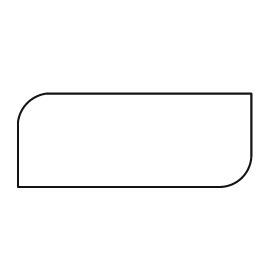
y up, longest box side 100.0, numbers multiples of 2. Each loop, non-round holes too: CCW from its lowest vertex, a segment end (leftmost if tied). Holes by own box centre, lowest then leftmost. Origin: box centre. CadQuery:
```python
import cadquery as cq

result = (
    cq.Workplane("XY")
    .moveTo(-50.0, -20.0)
    .lineTo(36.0, -20.0)
    .threePointArc((46.0, -16.0), (50.0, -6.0))
    .lineTo(50.0, 20.0)
    .lineTo(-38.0, 20.0)
    .threePointArc((-46.0, 16.0), (-50.0, 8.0))
    .close()
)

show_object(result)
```